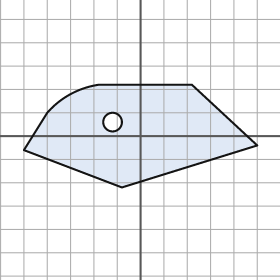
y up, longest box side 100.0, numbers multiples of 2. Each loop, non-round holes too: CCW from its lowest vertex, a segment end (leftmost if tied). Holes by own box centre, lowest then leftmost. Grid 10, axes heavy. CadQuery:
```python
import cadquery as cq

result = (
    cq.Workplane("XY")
    .moveTo(-8.0, -22.0)
    .lineTo(50.0, -4.0)
    .lineTo(22.0, 22.0)
    .lineTo(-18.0, 22.0)
    .threePointArc((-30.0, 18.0), (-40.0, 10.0))
    .lineTo(-50.0, -6.0)
    .close()
    .moveTo(-12.0, 6.0)
    .circle(4.0)
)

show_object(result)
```